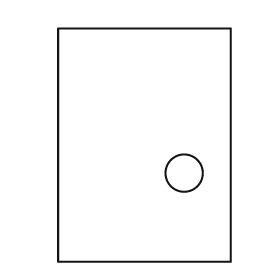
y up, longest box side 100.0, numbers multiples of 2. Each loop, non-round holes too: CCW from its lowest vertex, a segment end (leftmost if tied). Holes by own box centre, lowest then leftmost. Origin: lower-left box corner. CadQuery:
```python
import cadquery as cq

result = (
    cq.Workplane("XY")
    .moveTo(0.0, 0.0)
    .lineTo(74.0, 0.0)
    .lineTo(74.0, 100.0)
    .lineTo(0.0, 100.0)
    .close()
    .moveTo(54.0, 38.0)
    .circle(8.0)
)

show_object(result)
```